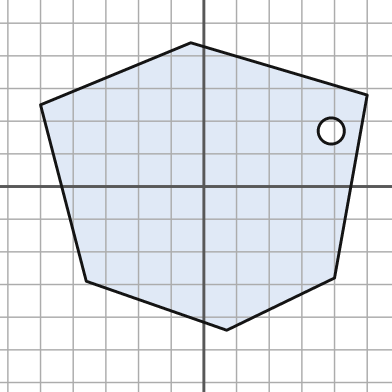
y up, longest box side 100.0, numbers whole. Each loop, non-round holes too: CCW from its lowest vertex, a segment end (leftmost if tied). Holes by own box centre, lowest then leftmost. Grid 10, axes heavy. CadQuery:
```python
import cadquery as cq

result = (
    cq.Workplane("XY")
    .moveTo(7.0, -44.0)
    .lineTo(40.0, -28.0)
    .lineTo(50.0, 28.0)
    .lineTo(-4.0, 44.0)
    .lineTo(-50.0, 25.0)
    .lineTo(-36.0, -29.0)
    .close()
    .moveTo(39.0, 17.0)
    .circle(4.0)
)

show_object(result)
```